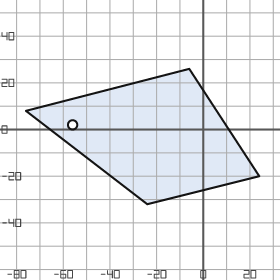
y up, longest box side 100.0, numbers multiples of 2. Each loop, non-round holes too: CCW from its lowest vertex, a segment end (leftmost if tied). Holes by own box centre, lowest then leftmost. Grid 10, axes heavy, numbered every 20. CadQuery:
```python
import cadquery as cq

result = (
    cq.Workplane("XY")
    .moveTo(-24.0, -32.0)
    .lineTo(24.0, -20.0)
    .lineTo(-6.0, 26.0)
    .lineTo(-76.0, 8.0)
    .close()
    .moveTo(-56.0, 2.0)
    .circle(2.0)
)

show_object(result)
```